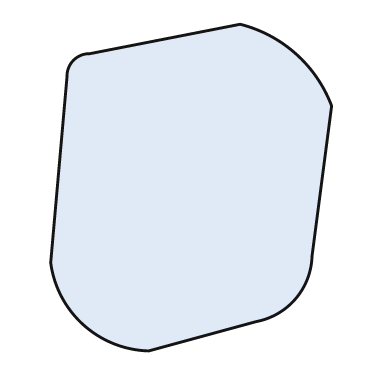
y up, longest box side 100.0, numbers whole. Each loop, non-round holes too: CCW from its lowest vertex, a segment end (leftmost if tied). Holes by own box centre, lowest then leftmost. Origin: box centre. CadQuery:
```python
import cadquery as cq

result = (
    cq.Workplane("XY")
    .moveTo(-13.0, -50.0)
    .lineTo(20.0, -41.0)
    .threePointArc((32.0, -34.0), (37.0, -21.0))
    .lineTo(43.0, 25.0)
    .threePointArc((32.0, 41.0), (15.0, 50.0))
    .lineTo(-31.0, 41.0)
    .threePointArc((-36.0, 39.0), (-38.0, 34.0))
    .lineTo(-43.0, -23.0)
    .threePointArc((-33.0, -42.0), (-13.0, -50.0))
    .close()
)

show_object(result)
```